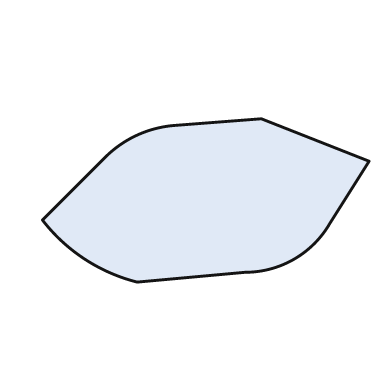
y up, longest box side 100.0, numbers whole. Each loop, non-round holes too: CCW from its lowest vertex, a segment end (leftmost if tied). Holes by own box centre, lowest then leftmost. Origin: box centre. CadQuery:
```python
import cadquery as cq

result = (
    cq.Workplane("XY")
    .moveTo(-21.0, -25.0)
    .lineTo(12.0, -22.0)
    .threePointArc((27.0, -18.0), (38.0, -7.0))
    .lineTo(50.0, 12.0)
    .lineTo(17.0, 25.0)
    .lineTo(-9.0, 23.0)
    .threePointArc((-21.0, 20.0), (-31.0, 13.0))
    .lineTo(-50.0, -6.0)
    .threePointArc((-37.0, -18.0), (-21.0, -25.0))
    .close()
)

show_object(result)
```